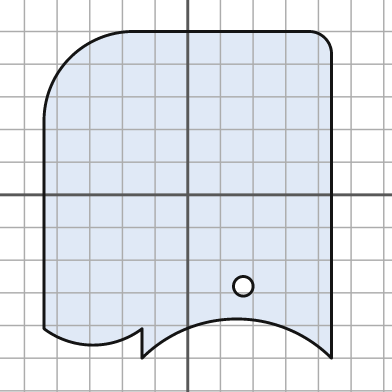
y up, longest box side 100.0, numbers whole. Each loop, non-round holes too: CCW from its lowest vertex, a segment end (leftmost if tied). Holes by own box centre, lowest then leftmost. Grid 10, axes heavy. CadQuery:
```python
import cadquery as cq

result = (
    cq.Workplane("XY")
    .moveTo(-14.0, -50.0)
    .threePointArc((15.0, -38.0), (44.0, -50.0))
    .lineTo(44.0, 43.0)
    .threePointArc((42.0, 48.0), (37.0, 50.0))
    .lineTo(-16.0, 50.0)
    .threePointArc((-36.0, 42.0), (-44.0, 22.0))
    .lineTo(-44.0, -41.0)
    .threePointArc((-29.0, -46.0), (-14.0, -41.0))
    .close()
    .moveTo(17.0, -28.0)
    .circle(3.0)
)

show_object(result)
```